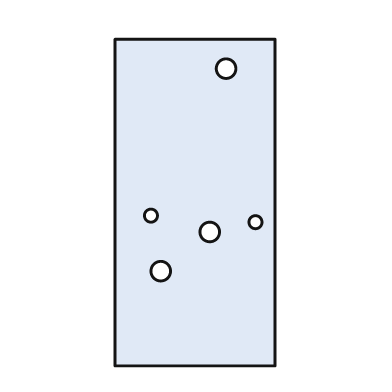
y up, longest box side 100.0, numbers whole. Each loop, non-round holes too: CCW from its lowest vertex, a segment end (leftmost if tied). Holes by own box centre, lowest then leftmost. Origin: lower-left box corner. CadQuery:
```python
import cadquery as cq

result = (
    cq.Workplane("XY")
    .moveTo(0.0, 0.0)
    .lineTo(49.0, 0.0)
    .lineTo(49.0, 100.0)
    .lineTo(0.0, 100.0)
    .close()
    .moveTo(14.0, 29.0)
    .circle(3.0)
    .moveTo(29.0, 41.0)
    .circle(3.0)
    .moveTo(43.0, 44.0)
    .circle(2.0)
    .moveTo(11.0, 46.0)
    .circle(2.0)
    .moveTo(34.0, 91.0)
    .circle(3.0)
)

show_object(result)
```